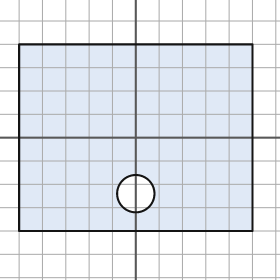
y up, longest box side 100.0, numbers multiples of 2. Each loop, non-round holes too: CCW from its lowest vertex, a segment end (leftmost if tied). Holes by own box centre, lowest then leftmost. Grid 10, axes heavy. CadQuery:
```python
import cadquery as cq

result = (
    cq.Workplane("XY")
    .moveTo(-50.0, -40.0)
    .lineTo(50.0, -40.0)
    .lineTo(50.0, 40.0)
    .lineTo(-50.0, 40.0)
    .close()
    .moveTo(0.0, -24.0)
    .circle(8.0)
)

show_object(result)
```